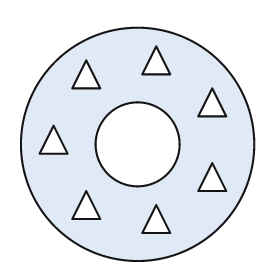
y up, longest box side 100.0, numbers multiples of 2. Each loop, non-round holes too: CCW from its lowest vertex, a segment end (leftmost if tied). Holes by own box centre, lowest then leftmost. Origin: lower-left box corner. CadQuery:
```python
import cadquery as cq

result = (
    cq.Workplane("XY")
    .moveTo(50.0, 50.0)
    .circle(50.0)
    .moveTo(52.0, 12.0)
    .lineTo(64.0, 12.0)
    .lineTo(58.0, 24.0)
    .close()
    .moveTo(22.0, 18.0)
    .lineTo(34.0, 18.0)
    .lineTo(28.0, 30.0)
    .close()
    .moveTo(76.0, 30.0)
    .lineTo(88.0, 30.0)
    .lineTo(82.0, 42.0)
    .close()
    .moveTo(50.0, 50.0)
    .circle(18.0)
    .moveTo(8.0, 46.0)
    .lineTo(20.0, 46.0)
    .lineTo(14.0, 58.0)
    .close()
    .moveTo(76.0, 62.0)
    .lineTo(88.0, 62.0)
    .lineTo(82.0, 74.0)
    .close()
    .moveTo(22.0, 74.0)
    .lineTo(34.0, 74.0)
    .lineTo(28.0, 86.0)
    .close()
    .moveTo(52.0, 80.0)
    .lineTo(64.0, 80.0)
    .lineTo(58.0, 92.0)
    .close()
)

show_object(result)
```